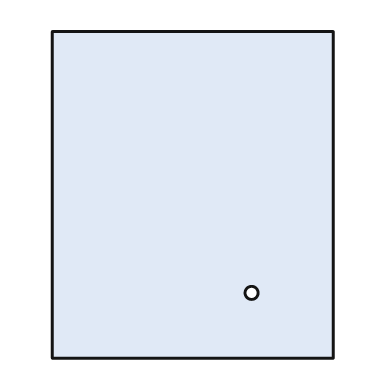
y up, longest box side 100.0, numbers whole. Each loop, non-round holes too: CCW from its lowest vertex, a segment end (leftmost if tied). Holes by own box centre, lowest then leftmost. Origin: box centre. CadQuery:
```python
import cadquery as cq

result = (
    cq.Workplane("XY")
    .moveTo(-43.0, -50.0)
    .lineTo(43.0, -50.0)
    .lineTo(43.0, 50.0)
    .lineTo(-43.0, 50.0)
    .close()
    .moveTo(18.0, -30.0)
    .circle(2.0)
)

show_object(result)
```